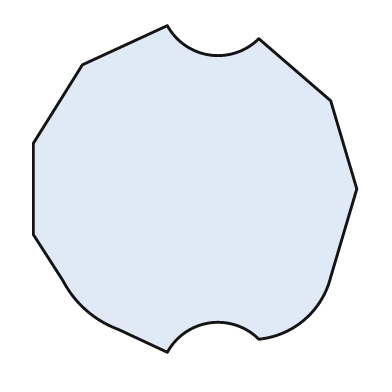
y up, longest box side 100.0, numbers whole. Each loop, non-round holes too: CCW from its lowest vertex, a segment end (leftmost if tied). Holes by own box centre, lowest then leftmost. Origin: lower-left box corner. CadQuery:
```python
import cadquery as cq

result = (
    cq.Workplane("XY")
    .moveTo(41.0, 0.0)
    .threePointArc((54.0, 9.0), (69.0, 4.0))
    .threePointArc((83.0, 10.0), (91.0, 23.0))
    .lineTo(99.0, 50.0)
    .lineTo(91.0, 77.0)
    .lineTo(69.0, 96.0)
    .threePointArc((54.0, 91.0), (41.0, 100.0))
    .lineTo(15.0, 88.0)
    .lineTo(0.0, 64.0)
    .lineTo(0.0, 36.0)
    .lineTo(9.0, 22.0)
    .threePointArc((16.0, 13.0), (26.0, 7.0))
    .close()
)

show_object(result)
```